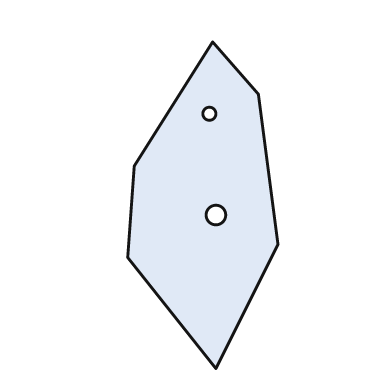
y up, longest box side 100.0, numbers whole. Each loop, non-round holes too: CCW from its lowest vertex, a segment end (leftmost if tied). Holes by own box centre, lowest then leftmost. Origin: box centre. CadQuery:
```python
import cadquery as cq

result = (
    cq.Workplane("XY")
    .moveTo(4.0, -50.0)
    .lineTo(23.0, -12.0)
    .lineTo(17.0, 34.0)
    .lineTo(3.0, 50.0)
    .lineTo(-21.0, 12.0)
    .lineTo(-23.0, -16.0)
    .close()
    .moveTo(4.0, -3.0)
    .circle(3.0)
    .moveTo(2.0, 28.0)
    .circle(2.0)
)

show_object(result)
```